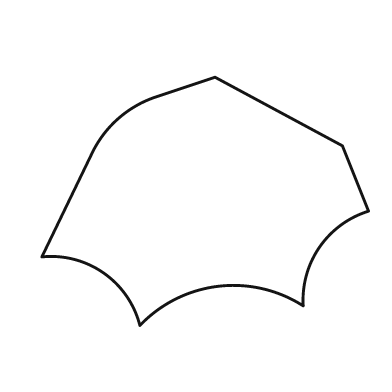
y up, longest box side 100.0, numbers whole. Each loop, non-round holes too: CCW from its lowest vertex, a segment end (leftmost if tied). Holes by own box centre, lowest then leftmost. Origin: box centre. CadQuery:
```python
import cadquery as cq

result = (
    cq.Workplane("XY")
    .moveTo(-20.0, -38.0)
    .threePointArc((4.0, -26.0), (30.0, -32.0))
    .threePointArc((35.0, -14.0), (50.0, -3.0))
    .lineTo(42.0, 17.0)
    .lineTo(3.0, 38.0)
    .lineTo(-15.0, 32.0)
    .threePointArc((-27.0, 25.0), (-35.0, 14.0))
    .lineTo(-50.0, -17.0)
    .threePointArc((-31.0, -22.0), (-20.0, -38.0))
    .close()
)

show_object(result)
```